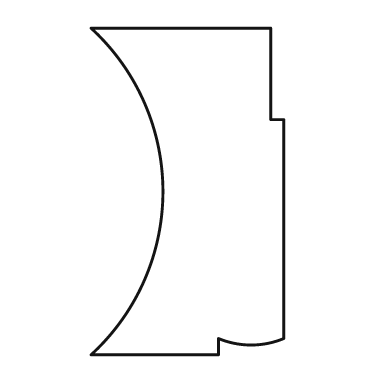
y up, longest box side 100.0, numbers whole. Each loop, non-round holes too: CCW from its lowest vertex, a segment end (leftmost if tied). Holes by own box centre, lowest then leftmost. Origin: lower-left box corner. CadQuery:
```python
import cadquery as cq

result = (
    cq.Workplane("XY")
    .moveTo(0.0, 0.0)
    .lineTo(39.0, 0.0)
    .lineTo(39.0, 5.0)
    .threePointArc((49.0, 3.0), (59.0, 5.0))
    .lineTo(59.0, 72.0)
    .lineTo(55.0, 72.0)
    .lineTo(55.0, 100.0)
    .lineTo(0.0, 100.0)
    .threePointArc((22.0, 50.0), (0.0, 0.0))
    .close()
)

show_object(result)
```